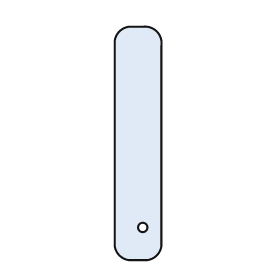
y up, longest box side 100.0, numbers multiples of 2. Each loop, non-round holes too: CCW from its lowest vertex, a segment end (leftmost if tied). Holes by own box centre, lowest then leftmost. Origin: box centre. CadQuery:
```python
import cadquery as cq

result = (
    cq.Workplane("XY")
    .moveTo(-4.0, -50.0)
    .lineTo(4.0, -50.0)
    .threePointArc((8.0, -48.0), (10.0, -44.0))
    .lineTo(10.0, 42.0)
    .threePointArc((8.0, 48.0), (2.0, 50.0))
    .lineTo(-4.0, 50.0)
    .threePointArc((-8.0, 48.0), (-10.0, 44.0))
    .lineTo(-10.0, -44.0)
    .threePointArc((-8.0, -48.0), (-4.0, -50.0))
    .close()
    .moveTo(2.0, -36.0)
    .circle(2.0)
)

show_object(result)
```